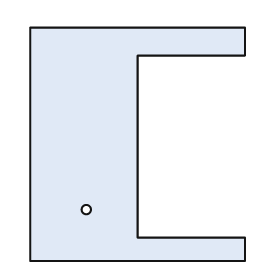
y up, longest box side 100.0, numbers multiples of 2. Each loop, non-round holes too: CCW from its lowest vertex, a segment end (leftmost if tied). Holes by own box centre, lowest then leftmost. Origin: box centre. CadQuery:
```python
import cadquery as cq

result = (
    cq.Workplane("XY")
    .moveTo(-46.0, -50.0)
    .lineTo(46.0, -50.0)
    .lineTo(46.0, -40.0)
    .lineTo(0.0, -40.0)
    .lineTo(0.0, 38.0)
    .lineTo(46.0, 38.0)
    .lineTo(46.0, 50.0)
    .lineTo(-46.0, 50.0)
    .close()
    .moveTo(-22.0, -28.0)
    .circle(2.0)
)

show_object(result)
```